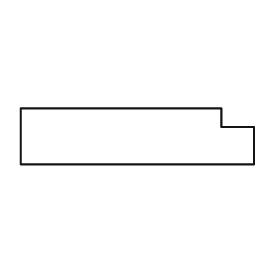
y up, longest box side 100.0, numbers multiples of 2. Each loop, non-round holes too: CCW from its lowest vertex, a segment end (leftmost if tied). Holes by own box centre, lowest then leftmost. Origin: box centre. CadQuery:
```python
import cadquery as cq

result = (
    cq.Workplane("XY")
    .moveTo(-50.0, -12.0)
    .lineTo(50.0, -12.0)
    .lineTo(50.0, 4.0)
    .lineTo(36.0, 4.0)
    .lineTo(36.0, 12.0)
    .lineTo(-50.0, 12.0)
    .close()
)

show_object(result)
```